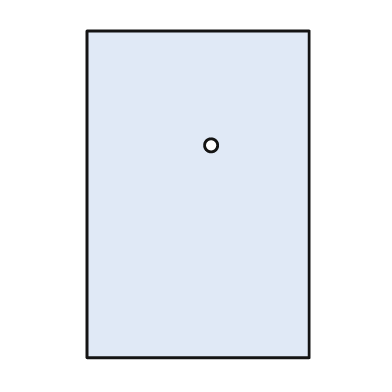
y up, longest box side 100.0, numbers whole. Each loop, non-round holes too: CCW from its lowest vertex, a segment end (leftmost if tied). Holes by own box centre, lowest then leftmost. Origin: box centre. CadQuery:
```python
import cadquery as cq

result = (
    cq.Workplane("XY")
    .moveTo(-34.0, -50.0)
    .lineTo(34.0, -50.0)
    .lineTo(34.0, 50.0)
    .lineTo(-34.0, 50.0)
    .close()
    .moveTo(4.0, 15.0)
    .circle(2.0)
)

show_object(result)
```